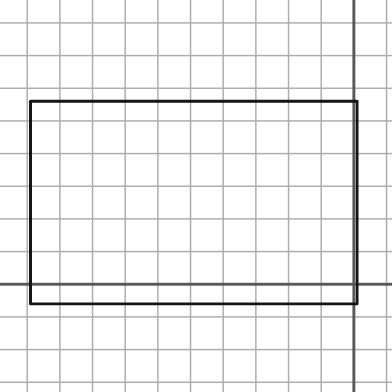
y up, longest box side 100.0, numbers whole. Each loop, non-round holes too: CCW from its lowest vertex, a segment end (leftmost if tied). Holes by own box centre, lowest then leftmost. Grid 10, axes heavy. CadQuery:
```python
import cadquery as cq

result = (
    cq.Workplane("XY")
    .moveTo(-99.0, -6.0)
    .lineTo(1.0, -6.0)
    .lineTo(1.0, 56.0)
    .lineTo(-99.0, 56.0)
    .close()
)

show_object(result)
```